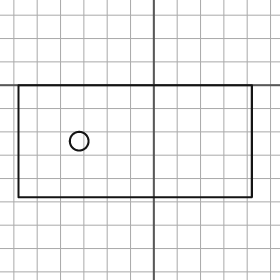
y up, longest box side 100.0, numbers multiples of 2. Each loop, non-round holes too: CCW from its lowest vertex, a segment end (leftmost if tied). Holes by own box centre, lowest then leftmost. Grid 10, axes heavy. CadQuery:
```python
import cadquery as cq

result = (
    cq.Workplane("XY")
    .moveTo(-58.0, -48.0)
    .lineTo(42.0, -48.0)
    .lineTo(42.0, 0.0)
    .lineTo(-58.0, 0.0)
    .close()
    .moveTo(-32.0, -24.0)
    .circle(4.0)
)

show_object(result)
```